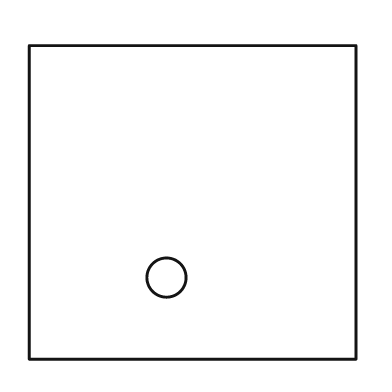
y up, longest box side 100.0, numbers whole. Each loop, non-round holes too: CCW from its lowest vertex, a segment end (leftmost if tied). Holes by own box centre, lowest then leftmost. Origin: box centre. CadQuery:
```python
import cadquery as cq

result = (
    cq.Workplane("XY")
    .moveTo(-50.0, -48.0)
    .lineTo(50.0, -48.0)
    .lineTo(50.0, 48.0)
    .lineTo(-50.0, 48.0)
    .close()
    .moveTo(-8.0, -23.0)
    .circle(6.0)
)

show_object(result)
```